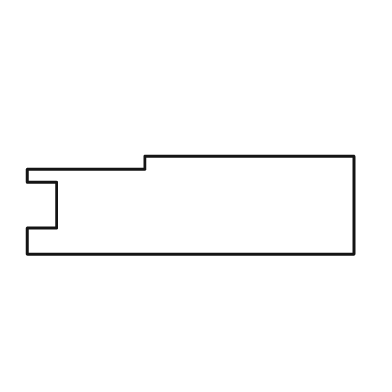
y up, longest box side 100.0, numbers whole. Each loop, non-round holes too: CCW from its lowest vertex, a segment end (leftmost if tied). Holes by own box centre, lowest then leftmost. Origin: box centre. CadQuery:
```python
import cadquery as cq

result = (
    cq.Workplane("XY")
    .moveTo(-50.0, -15.0)
    .lineTo(50.0, -15.0)
    .lineTo(50.0, 15.0)
    .lineTo(-14.0, 15.0)
    .lineTo(-14.0, 11.0)
    .lineTo(-50.0, 11.0)
    .lineTo(-50.0, 7.0)
    .lineTo(-41.0, 7.0)
    .lineTo(-41.0, -7.0)
    .lineTo(-50.0, -7.0)
    .close()
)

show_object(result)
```